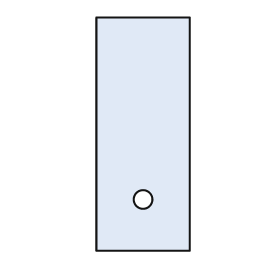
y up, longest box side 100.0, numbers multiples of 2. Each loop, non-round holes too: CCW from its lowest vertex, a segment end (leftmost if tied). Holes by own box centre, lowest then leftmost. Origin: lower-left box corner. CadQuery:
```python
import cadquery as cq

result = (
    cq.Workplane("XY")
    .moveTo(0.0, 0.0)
    .lineTo(40.0, 0.0)
    .lineTo(40.0, 100.0)
    .lineTo(0.0, 100.0)
    .close()
    .moveTo(20.0, 22.0)
    .circle(4.0)
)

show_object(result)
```